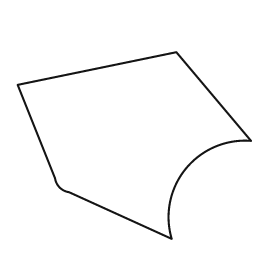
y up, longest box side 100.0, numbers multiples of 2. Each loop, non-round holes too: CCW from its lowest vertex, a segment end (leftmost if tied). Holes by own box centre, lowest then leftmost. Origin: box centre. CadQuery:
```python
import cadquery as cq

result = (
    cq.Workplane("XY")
    .moveTo(16.0, -40.0)
    .threePointArc((22.0, -10.0), (50.0, 2.0))
    .lineTo(18.0, 40.0)
    .lineTo(-50.0, 26.0)
    .lineTo(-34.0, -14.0)
    .threePointArc((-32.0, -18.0), (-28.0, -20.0))
    .close()
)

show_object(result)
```